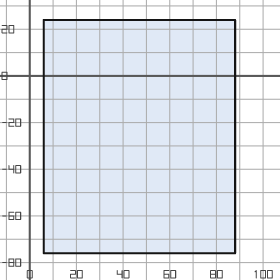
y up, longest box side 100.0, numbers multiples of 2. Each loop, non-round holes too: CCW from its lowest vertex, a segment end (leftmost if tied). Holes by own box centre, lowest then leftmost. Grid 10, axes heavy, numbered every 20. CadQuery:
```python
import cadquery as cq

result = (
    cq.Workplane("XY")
    .moveTo(6.0, -76.0)
    .lineTo(88.0, -76.0)
    .lineTo(88.0, 24.0)
    .lineTo(6.0, 24.0)
    .close()
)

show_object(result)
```